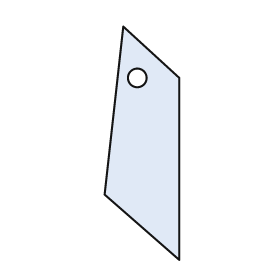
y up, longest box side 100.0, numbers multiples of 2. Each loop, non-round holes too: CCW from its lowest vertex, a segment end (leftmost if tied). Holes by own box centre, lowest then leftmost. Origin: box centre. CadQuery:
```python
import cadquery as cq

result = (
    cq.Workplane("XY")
    .moveTo(16.0, -50.0)
    .lineTo(16.0, 28.0)
    .lineTo(-8.0, 50.0)
    .lineTo(-16.0, -22.0)
    .close()
    .moveTo(-2.0, 28.0)
    .circle(4.0)
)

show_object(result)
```